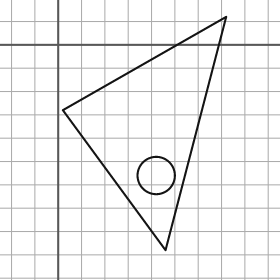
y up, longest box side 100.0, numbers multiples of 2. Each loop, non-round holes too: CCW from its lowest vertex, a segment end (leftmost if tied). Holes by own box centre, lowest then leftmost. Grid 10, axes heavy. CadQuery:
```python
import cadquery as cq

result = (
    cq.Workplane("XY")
    .moveTo(46.0, -88.0)
    .lineTo(72.0, 12.0)
    .lineTo(2.0, -28.0)
    .close()
    .moveTo(42.0, -56.0)
    .circle(8.0)
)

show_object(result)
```